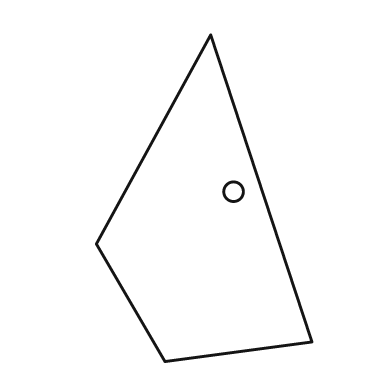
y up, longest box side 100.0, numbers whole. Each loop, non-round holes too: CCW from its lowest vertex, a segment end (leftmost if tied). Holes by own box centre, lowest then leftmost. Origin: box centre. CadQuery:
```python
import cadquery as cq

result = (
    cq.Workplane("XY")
    .moveTo(-12.0, -50.0)
    .lineTo(33.0, -44.0)
    .lineTo(2.0, 50.0)
    .lineTo(-33.0, -14.0)
    .close()
    .moveTo(9.0, 2.0)
    .circle(3.0)
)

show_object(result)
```